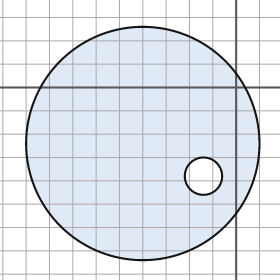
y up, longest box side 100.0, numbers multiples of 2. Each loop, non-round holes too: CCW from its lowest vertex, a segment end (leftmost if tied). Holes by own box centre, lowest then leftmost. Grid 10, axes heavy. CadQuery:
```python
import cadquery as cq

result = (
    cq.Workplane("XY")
    .moveTo(-40.0, -24.0)
    .circle(50.0)
    .moveTo(-14.0, -38.0)
    .circle(8.0)
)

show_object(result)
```